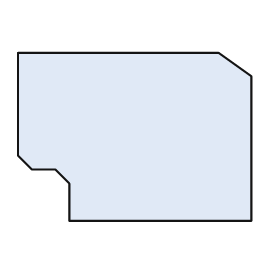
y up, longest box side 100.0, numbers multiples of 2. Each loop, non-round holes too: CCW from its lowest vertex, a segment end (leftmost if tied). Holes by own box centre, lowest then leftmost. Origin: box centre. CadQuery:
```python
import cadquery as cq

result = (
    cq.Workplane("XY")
    .moveTo(-28.0, -36.0)
    .lineTo(50.0, -36.0)
    .lineTo(50.0, 26.0)
    .lineTo(36.0, 36.0)
    .lineTo(-50.0, 36.0)
    .lineTo(-50.0, -8.0)
    .lineTo(-44.0, -14.0)
    .lineTo(-34.0, -14.0)
    .lineTo(-28.0, -20.0)
    .close()
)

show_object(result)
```